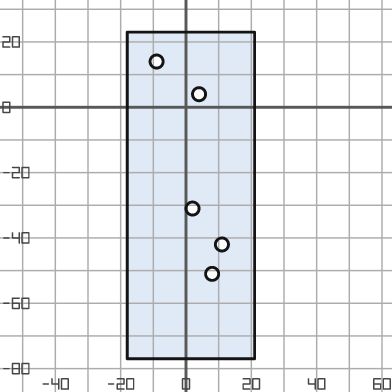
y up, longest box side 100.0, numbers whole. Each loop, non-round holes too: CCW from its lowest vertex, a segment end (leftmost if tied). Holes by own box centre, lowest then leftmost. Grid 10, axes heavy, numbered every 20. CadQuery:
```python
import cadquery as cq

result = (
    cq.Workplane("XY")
    .moveTo(-18.0, -77.0)
    .lineTo(21.0, -77.0)
    .lineTo(21.0, 23.0)
    .lineTo(-18.0, 23.0)
    .close()
    .moveTo(8.0, -51.0)
    .circle(2.0)
    .moveTo(11.0, -42.0)
    .circle(2.0)
    .moveTo(2.0, -31.0)
    .circle(2.0)
    .moveTo(4.0, 4.0)
    .circle(2.0)
    .moveTo(-9.0, 14.0)
    .circle(2.0)
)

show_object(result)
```